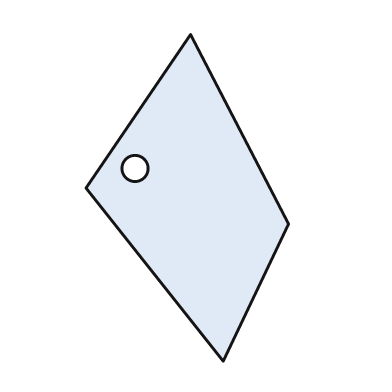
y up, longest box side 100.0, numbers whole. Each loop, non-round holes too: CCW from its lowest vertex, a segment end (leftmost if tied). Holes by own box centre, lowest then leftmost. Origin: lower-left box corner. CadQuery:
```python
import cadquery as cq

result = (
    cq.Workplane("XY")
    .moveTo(42.0, 0.0)
    .lineTo(62.0, 42.0)
    .lineTo(32.0, 100.0)
    .lineTo(0.0, 53.0)
    .close()
    .moveTo(15.0, 59.0)
    .circle(4.0)
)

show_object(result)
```